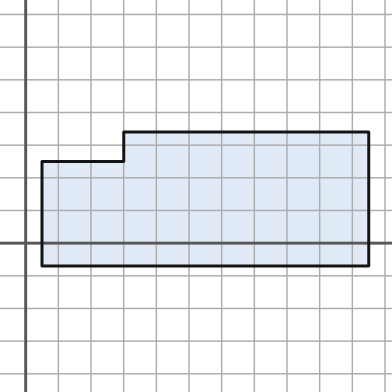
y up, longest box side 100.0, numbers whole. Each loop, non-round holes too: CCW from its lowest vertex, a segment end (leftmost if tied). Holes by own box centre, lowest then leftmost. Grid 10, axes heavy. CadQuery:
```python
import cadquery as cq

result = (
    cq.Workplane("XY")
    .moveTo(5.0, -7.0)
    .lineTo(105.0, -7.0)
    .lineTo(105.0, 34.0)
    .lineTo(30.0, 34.0)
    .lineTo(30.0, 25.0)
    .lineTo(5.0, 25.0)
    .close()
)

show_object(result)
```